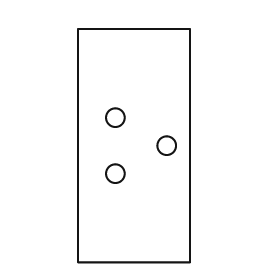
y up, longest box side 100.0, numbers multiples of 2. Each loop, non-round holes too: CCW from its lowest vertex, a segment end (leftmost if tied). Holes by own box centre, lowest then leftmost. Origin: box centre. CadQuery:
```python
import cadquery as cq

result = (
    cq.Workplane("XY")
    .moveTo(-24.0, -50.0)
    .lineTo(24.0, -50.0)
    .lineTo(24.0, 50.0)
    .lineTo(-24.0, 50.0)
    .close()
    .moveTo(-8.0, -12.0)
    .circle(4.0)
    .moveTo(14.0, 0.0)
    .circle(4.0)
    .moveTo(-8.0, 12.0)
    .circle(4.0)
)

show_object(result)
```